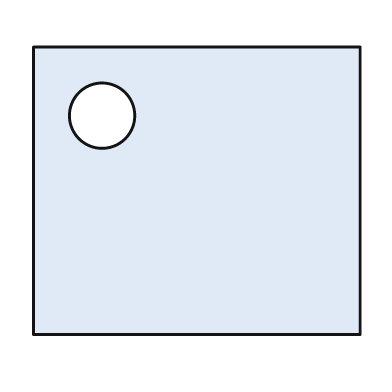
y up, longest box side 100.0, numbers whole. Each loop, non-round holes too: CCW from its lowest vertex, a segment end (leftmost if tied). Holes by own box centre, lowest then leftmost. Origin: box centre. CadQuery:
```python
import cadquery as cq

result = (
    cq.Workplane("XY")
    .moveTo(-50.0, -44.0)
    .lineTo(50.0, -44.0)
    .lineTo(50.0, 44.0)
    .lineTo(-50.0, 44.0)
    .close()
    .moveTo(-29.0, 23.0)
    .circle(10.0)
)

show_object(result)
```